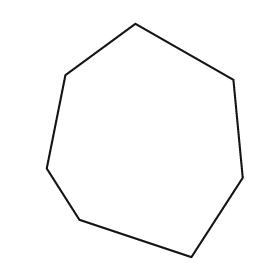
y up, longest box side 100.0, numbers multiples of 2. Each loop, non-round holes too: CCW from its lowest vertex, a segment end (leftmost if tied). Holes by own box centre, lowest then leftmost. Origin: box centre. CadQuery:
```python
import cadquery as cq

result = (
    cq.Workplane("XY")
    .moveTo(20.0, -50.0)
    .lineTo(42.0, -16.0)
    .lineTo(38.0, 26.0)
    .lineTo(-4.0, 50.0)
    .lineTo(-34.0, 28.0)
    .lineTo(-42.0, -12.0)
    .lineTo(-28.0, -34.0)
    .close()
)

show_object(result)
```